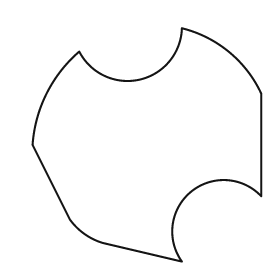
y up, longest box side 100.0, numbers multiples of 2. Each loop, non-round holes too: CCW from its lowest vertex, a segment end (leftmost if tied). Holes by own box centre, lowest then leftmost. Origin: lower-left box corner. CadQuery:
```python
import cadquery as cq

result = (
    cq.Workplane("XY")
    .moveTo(64.0, 0.0)
    .threePointArc((68.0, 30.0), (98.0, 28.0))
    .lineTo(98.0, 72.0)
    .threePointArc((84.0, 90.0), (64.0, 100.0))
    .threePointArc((46.0, 78.0), (20.0, 90.0))
    .threePointArc((6.0, 72.0), (0.0, 50.0))
    .lineTo(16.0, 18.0)
    .threePointArc((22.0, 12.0), (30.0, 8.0))
    .close()
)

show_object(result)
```